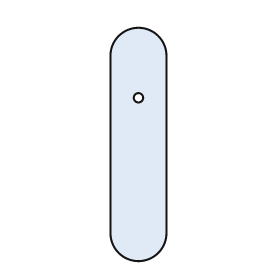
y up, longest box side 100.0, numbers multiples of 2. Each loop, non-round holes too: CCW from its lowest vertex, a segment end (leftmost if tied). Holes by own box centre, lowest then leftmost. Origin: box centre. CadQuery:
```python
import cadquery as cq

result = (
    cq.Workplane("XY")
    .moveTo(-12.0, -38.0)
    .threePointArc((0.0, -50.0), (12.0, -38.0))
    .lineTo(12.0, 38.0)
    .threePointArc((0.0, 50.0), (-12.0, 38.0))
    .close()
    .moveTo(0.0, 20.0)
    .circle(2.0)
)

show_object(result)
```